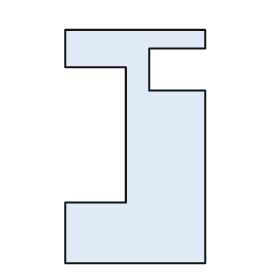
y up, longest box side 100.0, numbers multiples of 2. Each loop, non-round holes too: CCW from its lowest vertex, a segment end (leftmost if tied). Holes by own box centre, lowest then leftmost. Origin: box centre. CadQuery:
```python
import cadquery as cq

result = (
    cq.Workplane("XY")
    .moveTo(-30.0, -50.0)
    .lineTo(30.0, -50.0)
    .lineTo(30.0, 24.0)
    .lineTo(6.0, 24.0)
    .lineTo(6.0, 42.0)
    .lineTo(30.0, 42.0)
    .lineTo(30.0, 50.0)
    .lineTo(-30.0, 50.0)
    .lineTo(-30.0, 34.0)
    .lineTo(-4.0, 34.0)
    .lineTo(-4.0, -24.0)
    .lineTo(-30.0, -24.0)
    .close()
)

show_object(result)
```